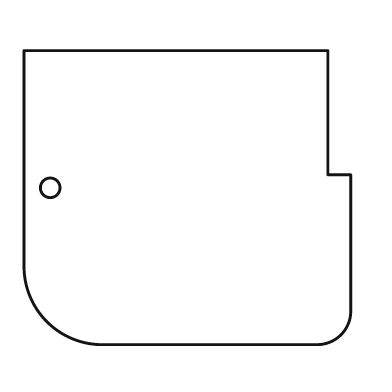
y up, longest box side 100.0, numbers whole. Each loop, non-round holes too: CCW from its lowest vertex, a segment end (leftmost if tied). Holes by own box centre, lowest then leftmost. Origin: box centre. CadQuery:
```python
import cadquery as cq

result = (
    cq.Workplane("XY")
    .moveTo(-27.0, -45.0)
    .lineTo(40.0, -45.0)
    .threePointArc((47.0, -42.0), (50.0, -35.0))
    .lineTo(50.0, 7.0)
    .lineTo(43.0, 7.0)
    .lineTo(43.0, 45.0)
    .lineTo(-50.0, 45.0)
    .lineTo(-50.0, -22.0)
    .threePointArc((-43.0, -38.0), (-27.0, -45.0))
    .close()
    .moveTo(-42.0, 3.0)
    .circle(3.0)
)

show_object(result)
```